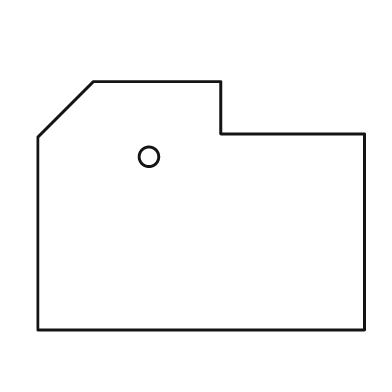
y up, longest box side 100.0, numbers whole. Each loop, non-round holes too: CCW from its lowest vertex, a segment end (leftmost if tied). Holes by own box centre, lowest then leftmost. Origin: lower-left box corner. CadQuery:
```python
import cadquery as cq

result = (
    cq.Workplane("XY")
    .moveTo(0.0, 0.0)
    .lineTo(100.0, 0.0)
    .lineTo(100.0, 60.0)
    .lineTo(56.0, 60.0)
    .lineTo(56.0, 76.0)
    .lineTo(17.0, 76.0)
    .lineTo(0.0, 59.0)
    .close()
    .moveTo(34.0, 53.0)
    .circle(3.0)
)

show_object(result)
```